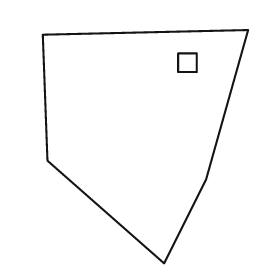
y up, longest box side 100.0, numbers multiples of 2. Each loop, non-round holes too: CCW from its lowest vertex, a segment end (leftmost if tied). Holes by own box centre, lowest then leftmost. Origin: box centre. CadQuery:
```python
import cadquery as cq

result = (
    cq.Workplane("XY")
    .moveTo(8.0, -50.0)
    .lineTo(26.0, -14.0)
    .lineTo(44.0, 50.0)
    .lineTo(-44.0, 48.0)
    .lineTo(-42.0, -6.0)
    .close()
    .moveTo(14.0, 32.0)
    .lineTo(22.0, 32.0)
    .lineTo(22.0, 40.0)
    .lineTo(14.0, 40.0)
    .close()
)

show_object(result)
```